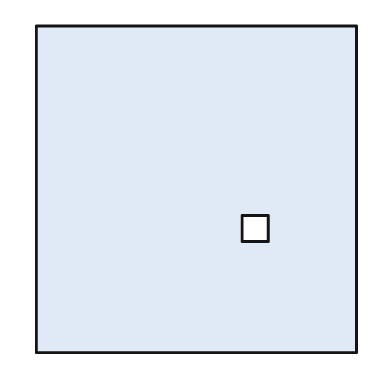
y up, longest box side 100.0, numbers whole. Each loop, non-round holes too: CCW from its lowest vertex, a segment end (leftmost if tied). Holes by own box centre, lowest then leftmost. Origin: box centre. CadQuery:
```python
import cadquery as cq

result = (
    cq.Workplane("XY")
    .moveTo(-49.0, -50.0)
    .lineTo(49.0, -50.0)
    .lineTo(49.0, 50.0)
    .lineTo(-49.0, 50.0)
    .close()
    .moveTo(14.0, -16.0)
    .lineTo(22.0, -16.0)
    .lineTo(22.0, -8.0)
    .lineTo(14.0, -8.0)
    .close()
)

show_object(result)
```